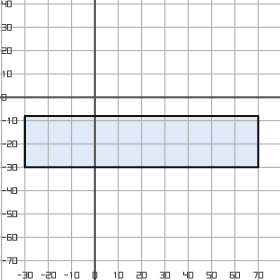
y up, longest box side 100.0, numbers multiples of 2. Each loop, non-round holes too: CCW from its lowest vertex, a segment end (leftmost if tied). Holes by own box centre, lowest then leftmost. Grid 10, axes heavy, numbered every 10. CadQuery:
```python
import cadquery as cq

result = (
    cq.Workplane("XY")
    .moveTo(-30.0, -30.0)
    .lineTo(70.0, -30.0)
    .lineTo(70.0, -8.0)
    .lineTo(-30.0, -8.0)
    .close()
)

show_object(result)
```